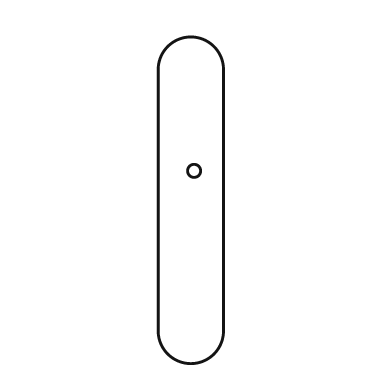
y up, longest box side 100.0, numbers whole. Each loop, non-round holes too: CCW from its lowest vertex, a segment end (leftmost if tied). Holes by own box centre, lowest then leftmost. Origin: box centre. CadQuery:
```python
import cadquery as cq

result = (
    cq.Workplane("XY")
    .moveTo(-10.0, -40.0)
    .threePointArc((0.0, -50.0), (10.0, -40.0))
    .lineTo(10.0, 40.0)
    .threePointArc((0.0, 50.0), (-10.0, 40.0))
    .close()
    .moveTo(1.0, 9.0)
    .circle(2.0)
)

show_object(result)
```